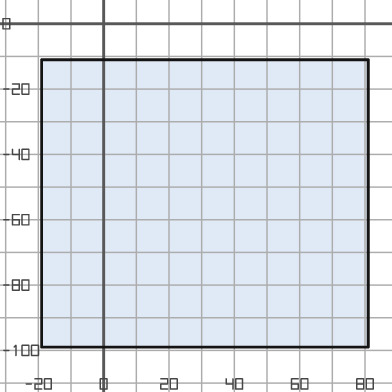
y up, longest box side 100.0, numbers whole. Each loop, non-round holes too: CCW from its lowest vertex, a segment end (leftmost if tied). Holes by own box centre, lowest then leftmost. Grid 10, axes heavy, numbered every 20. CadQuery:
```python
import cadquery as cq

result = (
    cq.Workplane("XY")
    .moveTo(-19.0, -99.0)
    .lineTo(81.0, -99.0)
    .lineTo(81.0, -11.0)
    .lineTo(-19.0, -11.0)
    .close()
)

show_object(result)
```